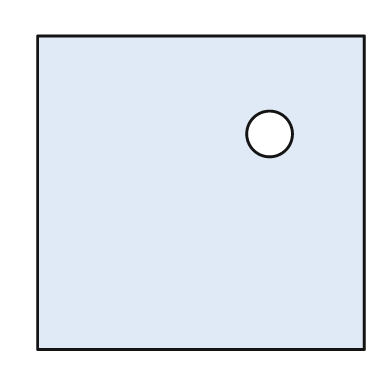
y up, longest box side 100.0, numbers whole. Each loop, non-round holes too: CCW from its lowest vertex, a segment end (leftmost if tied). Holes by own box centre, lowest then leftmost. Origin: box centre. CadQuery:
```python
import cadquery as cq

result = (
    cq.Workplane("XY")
    .moveTo(-50.0, -48.0)
    .lineTo(50.0, -48.0)
    .lineTo(50.0, 48.0)
    .lineTo(-50.0, 48.0)
    .close()
    .moveTo(21.0, 18.0)
    .circle(7.0)
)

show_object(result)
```